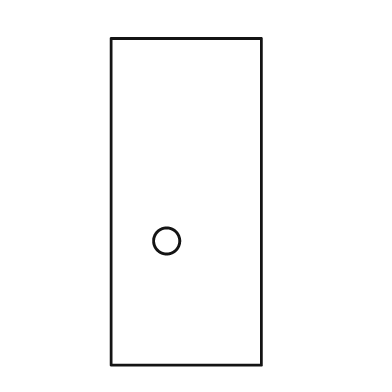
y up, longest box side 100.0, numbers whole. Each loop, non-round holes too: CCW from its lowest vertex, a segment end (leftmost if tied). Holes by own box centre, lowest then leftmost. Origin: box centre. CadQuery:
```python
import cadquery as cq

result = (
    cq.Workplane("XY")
    .moveTo(-23.0, -50.0)
    .lineTo(23.0, -50.0)
    .lineTo(23.0, 50.0)
    .lineTo(-23.0, 50.0)
    .close()
    .moveTo(-6.0, -12.0)
    .circle(4.0)
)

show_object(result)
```